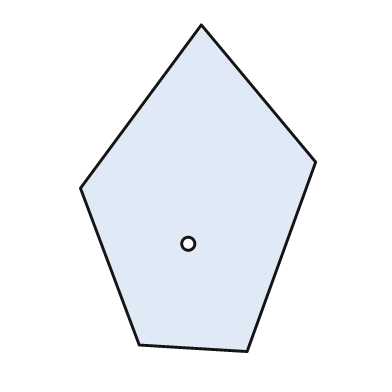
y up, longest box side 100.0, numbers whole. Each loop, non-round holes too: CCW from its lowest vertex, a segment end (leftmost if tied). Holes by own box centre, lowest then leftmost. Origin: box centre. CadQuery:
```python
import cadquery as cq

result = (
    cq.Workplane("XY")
    .moveTo(15.0, -50.0)
    .lineTo(36.0, 8.0)
    .lineTo(1.0, 50.0)
    .lineTo(-36.0, 0.0)
    .lineTo(-18.0, -48.0)
    .close()
    .moveTo(-3.0, -17.0)
    .circle(2.0)
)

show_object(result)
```